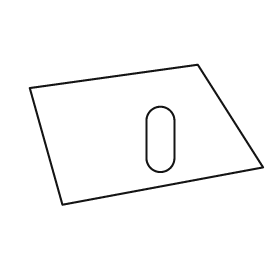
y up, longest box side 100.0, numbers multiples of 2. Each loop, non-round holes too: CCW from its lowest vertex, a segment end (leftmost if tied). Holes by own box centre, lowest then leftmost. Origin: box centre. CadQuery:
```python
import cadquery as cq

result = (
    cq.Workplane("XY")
    .moveTo(-36.0, -30.0)
    .lineTo(50.0, -14.0)
    .lineTo(22.0, 30.0)
    .lineTo(-50.0, 20.0)
    .close()
    .moveTo(0.0, -10.0)
    .threePointArc((6.0, -16.0), (12.0, -10.0))
    .lineTo(12.0, 6.0)
    .threePointArc((6.0, 12.0), (0.0, 6.0))
    .close()
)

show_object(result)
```